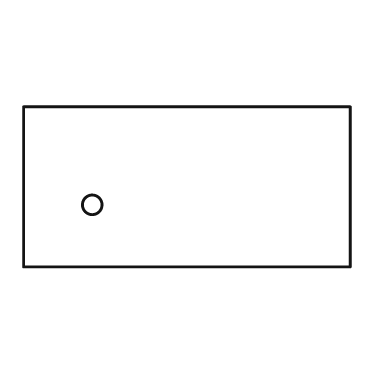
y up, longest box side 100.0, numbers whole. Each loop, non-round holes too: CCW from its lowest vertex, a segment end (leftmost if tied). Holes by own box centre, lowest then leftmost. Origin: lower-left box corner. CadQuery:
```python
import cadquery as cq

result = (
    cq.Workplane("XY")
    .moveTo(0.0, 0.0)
    .lineTo(100.0, 0.0)
    .lineTo(100.0, 49.0)
    .lineTo(0.0, 49.0)
    .close()
    .moveTo(21.0, 19.0)
    .circle(3.0)
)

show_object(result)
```